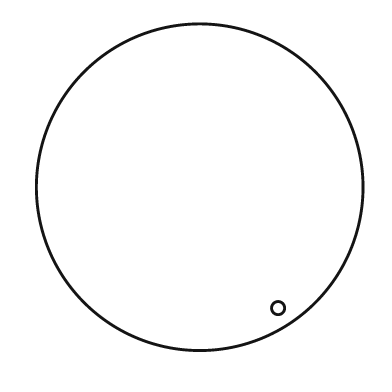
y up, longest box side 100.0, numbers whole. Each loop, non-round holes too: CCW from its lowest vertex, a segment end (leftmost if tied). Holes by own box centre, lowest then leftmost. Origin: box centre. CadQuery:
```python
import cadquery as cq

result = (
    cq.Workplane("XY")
    .moveTo(0.0, 0.0)
    .circle(50.0)
    .moveTo(24.0, -37.0)
    .circle(2.0)
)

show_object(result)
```